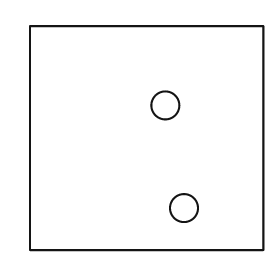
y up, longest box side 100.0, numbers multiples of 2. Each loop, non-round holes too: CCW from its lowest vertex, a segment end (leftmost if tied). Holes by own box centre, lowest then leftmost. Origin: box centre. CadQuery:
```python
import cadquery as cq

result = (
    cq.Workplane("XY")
    .moveTo(-50.0, -48.0)
    .lineTo(50.0, -48.0)
    .lineTo(50.0, 48.0)
    .lineTo(-50.0, 48.0)
    .close()
    .moveTo(16.0, -30.0)
    .circle(6.0)
    .moveTo(8.0, 14.0)
    .circle(6.0)
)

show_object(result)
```